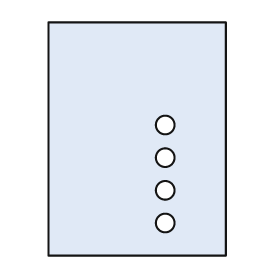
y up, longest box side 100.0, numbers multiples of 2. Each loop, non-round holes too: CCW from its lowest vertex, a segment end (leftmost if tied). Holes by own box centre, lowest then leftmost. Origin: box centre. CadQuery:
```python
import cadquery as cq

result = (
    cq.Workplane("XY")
    .moveTo(-38.0, -50.0)
    .lineTo(38.0, -50.0)
    .lineTo(38.0, 50.0)
    .lineTo(-38.0, 50.0)
    .close()
    .moveTo(12.0, -36.0)
    .circle(4.0)
    .moveTo(12.0, -22.0)
    .circle(4.0)
    .moveTo(12.0, -8.0)
    .circle(4.0)
    .moveTo(12.0, 6.0)
    .circle(4.0)
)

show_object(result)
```